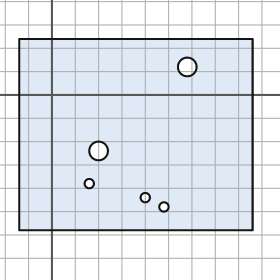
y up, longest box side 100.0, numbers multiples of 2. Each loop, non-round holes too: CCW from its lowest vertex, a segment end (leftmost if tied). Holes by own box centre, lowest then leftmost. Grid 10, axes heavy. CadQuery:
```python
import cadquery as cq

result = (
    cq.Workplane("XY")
    .moveTo(-14.0, -58.0)
    .lineTo(86.0, -58.0)
    .lineTo(86.0, 24.0)
    .lineTo(-14.0, 24.0)
    .close()
    .moveTo(48.0, -48.0)
    .circle(2.0)
    .moveTo(40.0, -44.0)
    .circle(2.0)
    .moveTo(16.0, -38.0)
    .circle(2.0)
    .moveTo(20.0, -24.0)
    .circle(4.0)
    .moveTo(58.0, 12.0)
    .circle(4.0)
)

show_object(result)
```